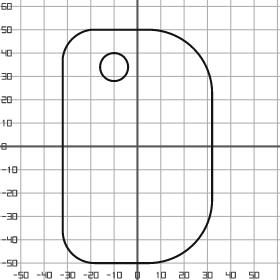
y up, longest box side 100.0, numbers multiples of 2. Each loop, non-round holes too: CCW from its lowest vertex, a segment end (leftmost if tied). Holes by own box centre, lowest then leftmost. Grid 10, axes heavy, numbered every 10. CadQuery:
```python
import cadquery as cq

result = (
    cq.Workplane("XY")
    .moveTo(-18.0, -50.0)
    .lineTo(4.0, -50.0)
    .threePointArc((24.0, -42.0), (32.0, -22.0))
    .lineTo(32.0, 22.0)
    .threePointArc((24.0, 42.0), (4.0, 50.0))
    .lineTo(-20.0, 50.0)
    .threePointArc((-28.0, 46.0), (-32.0, 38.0))
    .lineTo(-32.0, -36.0)
    .threePointArc((-28.0, -46.0), (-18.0, -50.0))
    .close()
    .moveTo(-10.0, 34.0)
    .circle(6.0)
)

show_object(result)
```